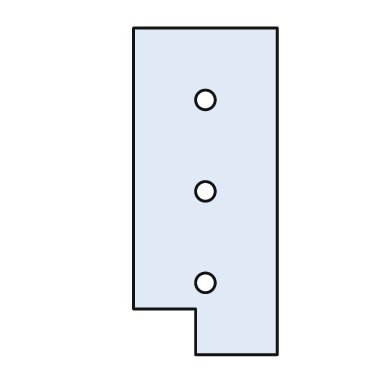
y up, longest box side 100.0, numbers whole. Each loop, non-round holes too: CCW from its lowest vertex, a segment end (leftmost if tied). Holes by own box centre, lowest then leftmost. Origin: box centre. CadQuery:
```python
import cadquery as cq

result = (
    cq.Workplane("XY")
    .moveTo(-3.0, -50.0)
    .lineTo(22.0, -50.0)
    .lineTo(22.0, 50.0)
    .lineTo(-22.0, 50.0)
    .lineTo(-22.0, -36.0)
    .lineTo(-3.0, -36.0)
    .close()
    .moveTo(0.0, -28.0)
    .circle(3.0)
    .moveTo(0.0, 0.0)
    .circle(3.0)
    .moveTo(0.0, 28.0)
    .circle(3.0)
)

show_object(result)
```